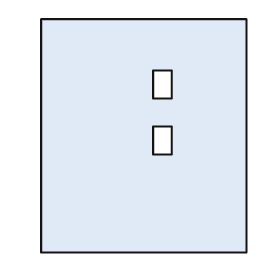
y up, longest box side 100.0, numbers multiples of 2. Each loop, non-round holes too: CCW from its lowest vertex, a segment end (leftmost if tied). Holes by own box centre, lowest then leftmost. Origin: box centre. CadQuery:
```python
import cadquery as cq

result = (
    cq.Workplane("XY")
    .moveTo(-44.0, -50.0)
    .lineTo(44.0, -50.0)
    .lineTo(44.0, 50.0)
    .lineTo(-44.0, 50.0)
    .close()
    .moveTo(4.0, -8.0)
    .lineTo(12.0, -8.0)
    .lineTo(12.0, 4.0)
    .lineTo(4.0, 4.0)
    .close()
    .moveTo(4.0, 16.0)
    .lineTo(12.0, 16.0)
    .lineTo(12.0, 28.0)
    .lineTo(4.0, 28.0)
    .close()
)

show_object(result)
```